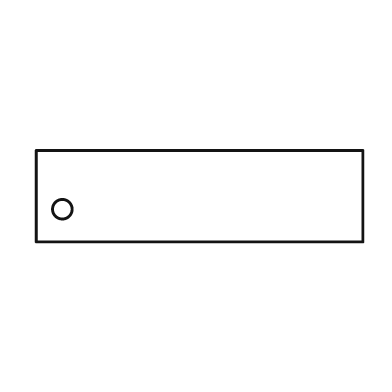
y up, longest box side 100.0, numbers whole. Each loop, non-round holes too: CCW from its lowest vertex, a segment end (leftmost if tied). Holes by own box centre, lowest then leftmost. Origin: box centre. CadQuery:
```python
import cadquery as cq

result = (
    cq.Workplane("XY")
    .moveTo(-50.0, -14.0)
    .lineTo(50.0, -14.0)
    .lineTo(50.0, 14.0)
    .lineTo(-50.0, 14.0)
    .close()
    .moveTo(-42.0, -4.0)
    .circle(3.0)
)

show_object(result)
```